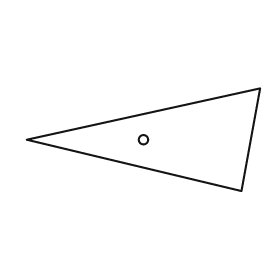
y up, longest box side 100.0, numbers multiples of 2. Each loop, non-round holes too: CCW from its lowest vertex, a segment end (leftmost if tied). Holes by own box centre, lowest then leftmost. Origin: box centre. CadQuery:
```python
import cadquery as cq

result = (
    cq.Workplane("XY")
    .moveTo(42.0, -22.0)
    .lineTo(50.0, 22.0)
    .lineTo(-50.0, 0.0)
    .close()
    .moveTo(0.0, 0.0)
    .circle(2.0)
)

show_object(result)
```